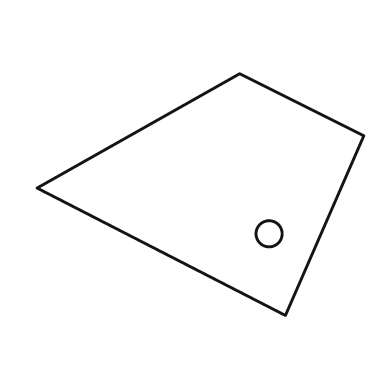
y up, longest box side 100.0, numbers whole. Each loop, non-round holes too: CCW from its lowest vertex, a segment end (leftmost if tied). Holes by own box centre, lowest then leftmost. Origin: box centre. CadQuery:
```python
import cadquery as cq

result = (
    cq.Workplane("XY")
    .moveTo(26.0, -37.0)
    .lineTo(50.0, 18.0)
    .lineTo(12.0, 37.0)
    .lineTo(-50.0, 2.0)
    .close()
    .moveTo(21.0, -12.0)
    .circle(4.0)
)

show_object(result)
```